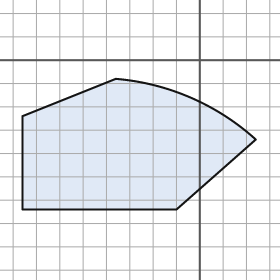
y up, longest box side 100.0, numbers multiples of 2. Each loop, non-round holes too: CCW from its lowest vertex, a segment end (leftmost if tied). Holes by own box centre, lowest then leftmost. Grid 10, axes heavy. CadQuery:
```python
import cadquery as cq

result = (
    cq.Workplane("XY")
    .moveTo(-76.0, -64.0)
    .lineTo(-10.0, -64.0)
    .lineTo(24.0, -34.0)
    .threePointArc((-4.0, -16.0), (-36.0, -8.0))
    .lineTo(-76.0, -24.0)
    .close()
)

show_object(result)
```